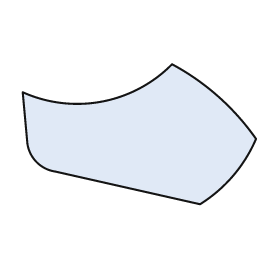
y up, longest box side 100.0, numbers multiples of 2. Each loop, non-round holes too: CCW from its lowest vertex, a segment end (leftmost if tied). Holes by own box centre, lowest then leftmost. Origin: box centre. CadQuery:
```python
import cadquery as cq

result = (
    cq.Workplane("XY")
    .moveTo(26.0, -30.0)
    .threePointArc((40.0, -18.0), (50.0, -2.0))
    .threePointArc((34.0, 16.0), (14.0, 30.0))
    .threePointArc((-16.0, 14.0), (-50.0, 18.0))
    .lineTo(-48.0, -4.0)
    .threePointArc((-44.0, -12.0), (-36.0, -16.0))
    .close()
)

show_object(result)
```